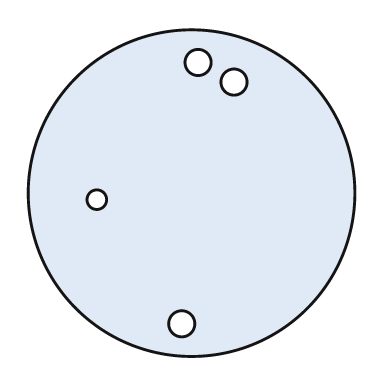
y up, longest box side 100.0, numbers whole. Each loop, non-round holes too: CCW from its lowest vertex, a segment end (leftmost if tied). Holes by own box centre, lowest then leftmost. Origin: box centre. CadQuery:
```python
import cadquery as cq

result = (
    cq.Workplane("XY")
    .moveTo(0.0, 0.0)
    .circle(50.0)
    .moveTo(-3.0, -40.0)
    .circle(4.0)
    .moveTo(-29.0, -2.0)
    .circle(3.0)
    .moveTo(13.0, 34.0)
    .circle(4.0)
    .moveTo(2.0, 40.0)
    .circle(4.0)
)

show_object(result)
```